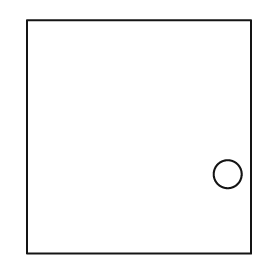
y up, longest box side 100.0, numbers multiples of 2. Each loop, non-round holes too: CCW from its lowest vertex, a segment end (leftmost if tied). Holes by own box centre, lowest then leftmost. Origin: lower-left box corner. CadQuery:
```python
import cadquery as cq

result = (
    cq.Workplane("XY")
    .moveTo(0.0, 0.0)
    .lineTo(96.0, 0.0)
    .lineTo(96.0, 100.0)
    .lineTo(0.0, 100.0)
    .close()
    .moveTo(86.0, 34.0)
    .circle(6.0)
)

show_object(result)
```